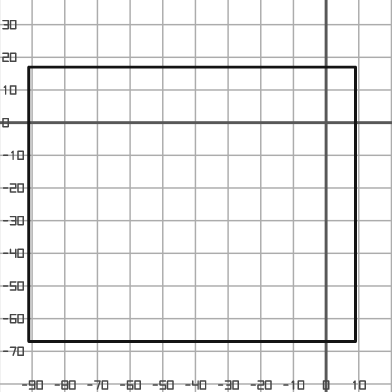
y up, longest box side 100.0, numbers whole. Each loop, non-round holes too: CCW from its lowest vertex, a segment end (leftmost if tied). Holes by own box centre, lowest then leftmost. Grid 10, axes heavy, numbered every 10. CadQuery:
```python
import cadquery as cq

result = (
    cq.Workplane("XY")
    .moveTo(-91.0, -67.0)
    .lineTo(9.0, -67.0)
    .lineTo(9.0, 17.0)
    .lineTo(-91.0, 17.0)
    .close()
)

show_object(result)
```